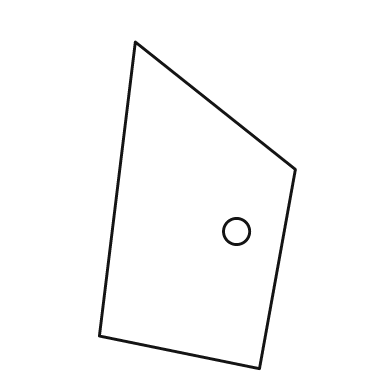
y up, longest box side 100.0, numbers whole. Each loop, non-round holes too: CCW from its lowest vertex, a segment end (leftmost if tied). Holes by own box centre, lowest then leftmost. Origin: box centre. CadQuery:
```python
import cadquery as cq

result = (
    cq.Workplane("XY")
    .moveTo(19.0, -50.0)
    .lineTo(30.0, 11.0)
    .lineTo(-19.0, 50.0)
    .lineTo(-30.0, -40.0)
    .close()
    .moveTo(12.0, -8.0)
    .circle(4.0)
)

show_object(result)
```